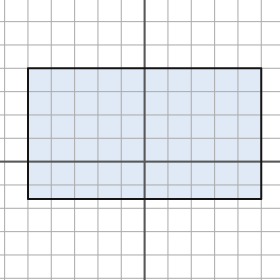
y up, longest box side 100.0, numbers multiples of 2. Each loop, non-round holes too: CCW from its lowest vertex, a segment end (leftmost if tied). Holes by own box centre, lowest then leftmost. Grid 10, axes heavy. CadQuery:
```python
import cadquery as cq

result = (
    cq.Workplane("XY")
    .moveTo(-50.0, -16.0)
    .lineTo(50.0, -16.0)
    .lineTo(50.0, 40.0)
    .lineTo(-50.0, 40.0)
    .close()
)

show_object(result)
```